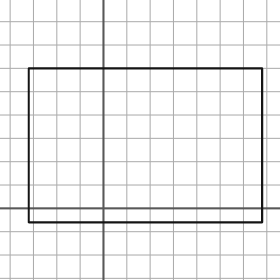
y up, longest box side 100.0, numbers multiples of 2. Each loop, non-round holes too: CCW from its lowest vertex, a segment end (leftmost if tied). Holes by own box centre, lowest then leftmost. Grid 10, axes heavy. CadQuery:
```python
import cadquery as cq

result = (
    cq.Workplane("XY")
    .moveTo(-32.0, -6.0)
    .lineTo(68.0, -6.0)
    .lineTo(68.0, 60.0)
    .lineTo(-32.0, 60.0)
    .close()
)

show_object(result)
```